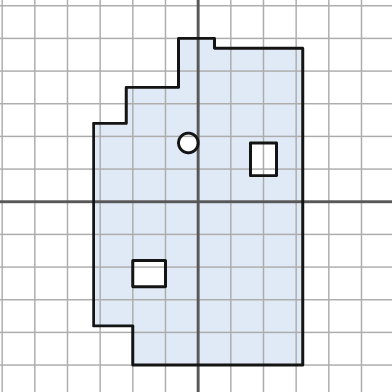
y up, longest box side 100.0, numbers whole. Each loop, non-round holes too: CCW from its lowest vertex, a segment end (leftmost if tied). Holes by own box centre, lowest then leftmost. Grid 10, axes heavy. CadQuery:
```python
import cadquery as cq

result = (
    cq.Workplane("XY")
    .moveTo(-20.0, -50.0)
    .lineTo(32.0, -50.0)
    .lineTo(32.0, 47.0)
    .lineTo(5.0, 47.0)
    .lineTo(5.0, 50.0)
    .lineTo(-6.0, 50.0)
    .lineTo(-6.0, 35.0)
    .lineTo(-22.0, 35.0)
    .lineTo(-22.0, 24.0)
    .lineTo(-32.0, 24.0)
    .lineTo(-32.0, -38.0)
    .lineTo(-20.0, -38.0)
    .close()
    .moveTo(-20.0, -26.0)
    .lineTo(-10.0, -26.0)
    .lineTo(-10.0, -18.0)
    .lineTo(-20.0, -18.0)
    .close()
    .moveTo(16.0, 8.0)
    .lineTo(24.0, 8.0)
    .lineTo(24.0, 18.0)
    .lineTo(16.0, 18.0)
    .close()
    .moveTo(-3.0, 18.0)
    .circle(3.0)
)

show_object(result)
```